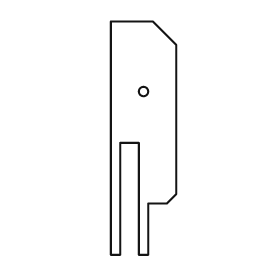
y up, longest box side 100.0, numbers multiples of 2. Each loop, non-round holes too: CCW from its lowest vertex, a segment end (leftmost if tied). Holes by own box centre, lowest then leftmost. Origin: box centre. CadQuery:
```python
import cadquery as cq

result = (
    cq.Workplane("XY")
    .moveTo(-14.0, -50.0)
    .lineTo(-10.0, -50.0)
    .lineTo(-10.0, -2.0)
    .lineTo(-2.0, -2.0)
    .lineTo(-2.0, -50.0)
    .lineTo(2.0, -50.0)
    .lineTo(2.0, -28.0)
    .lineTo(10.0, -28.0)
    .lineTo(14.0, -24.0)
    .lineTo(14.0, 40.0)
    .lineTo(4.0, 50.0)
    .lineTo(-14.0, 50.0)
    .close()
    .moveTo(0.0, 20.0)
    .circle(2.0)
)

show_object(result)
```